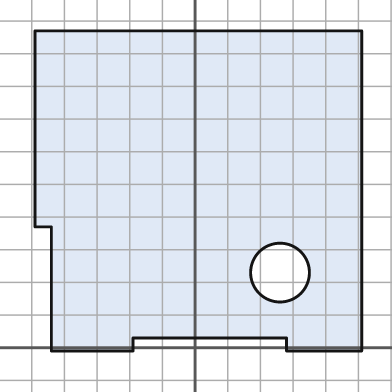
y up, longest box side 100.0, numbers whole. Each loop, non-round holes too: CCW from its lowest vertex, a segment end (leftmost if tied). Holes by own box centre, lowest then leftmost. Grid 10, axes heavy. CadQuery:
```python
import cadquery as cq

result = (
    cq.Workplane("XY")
    .moveTo(-44.0, -1.0)
    .lineTo(-19.0, -1.0)
    .lineTo(-19.0, 3.0)
    .lineTo(28.0, 3.0)
    .lineTo(28.0, -1.0)
    .lineTo(51.0, -1.0)
    .lineTo(51.0, 97.0)
    .lineTo(-49.0, 97.0)
    .lineTo(-49.0, 37.0)
    .lineTo(-44.0, 37.0)
    .close()
    .moveTo(26.0, 23.0)
    .circle(9.0)
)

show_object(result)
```